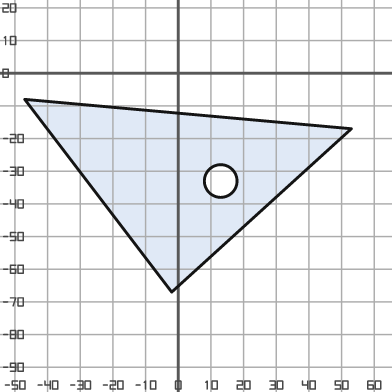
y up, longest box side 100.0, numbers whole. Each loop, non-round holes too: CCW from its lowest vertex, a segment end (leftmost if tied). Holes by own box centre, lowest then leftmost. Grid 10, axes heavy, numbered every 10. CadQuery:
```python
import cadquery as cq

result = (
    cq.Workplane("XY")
    .moveTo(-2.0, -67.0)
    .lineTo(53.0, -17.0)
    .lineTo(-47.0, -8.0)
    .close()
    .moveTo(13.0, -33.0)
    .circle(5.0)
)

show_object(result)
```